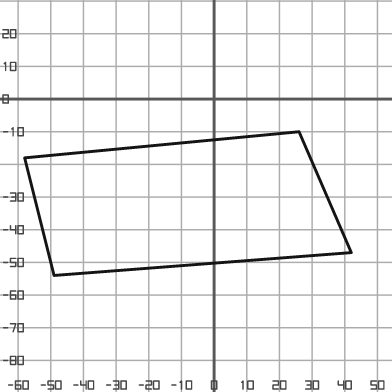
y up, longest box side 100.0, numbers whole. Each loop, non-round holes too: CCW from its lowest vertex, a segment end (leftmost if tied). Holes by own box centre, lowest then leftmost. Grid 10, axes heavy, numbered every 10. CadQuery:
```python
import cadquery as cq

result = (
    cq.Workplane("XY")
    .moveTo(-49.0, -54.0)
    .lineTo(42.0, -47.0)
    .lineTo(26.0, -10.0)
    .lineTo(-58.0, -18.0)
    .close()
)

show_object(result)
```